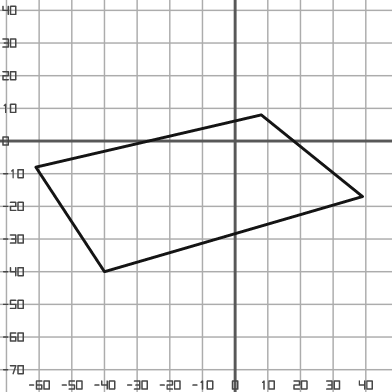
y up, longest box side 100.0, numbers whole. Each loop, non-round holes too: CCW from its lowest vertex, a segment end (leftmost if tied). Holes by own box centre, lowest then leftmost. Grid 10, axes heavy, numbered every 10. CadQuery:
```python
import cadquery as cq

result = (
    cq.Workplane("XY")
    .moveTo(-40.0, -40.0)
    .lineTo(39.0, -17.0)
    .lineTo(8.0, 8.0)
    .lineTo(-61.0, -8.0)
    .close()
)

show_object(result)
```